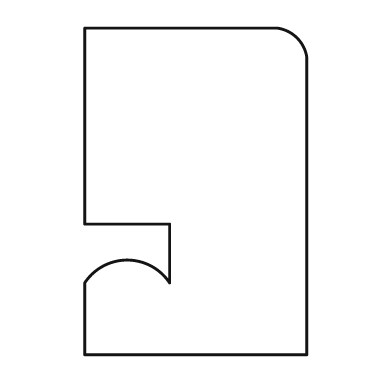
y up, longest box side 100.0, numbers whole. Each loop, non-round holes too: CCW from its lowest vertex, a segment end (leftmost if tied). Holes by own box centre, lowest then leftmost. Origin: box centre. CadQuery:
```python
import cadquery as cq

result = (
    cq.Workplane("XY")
    .moveTo(-34.0, -50.0)
    .lineTo(34.0, -50.0)
    .lineTo(34.0, 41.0)
    .threePointArc((31.0, 47.0), (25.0, 50.0))
    .lineTo(-34.0, 50.0)
    .lineTo(-34.0, -10.0)
    .lineTo(-8.0, -10.0)
    .lineTo(-8.0, -28.0)
    .threePointArc((-21.0, -21.0), (-34.0, -28.0))
    .close()
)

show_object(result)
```